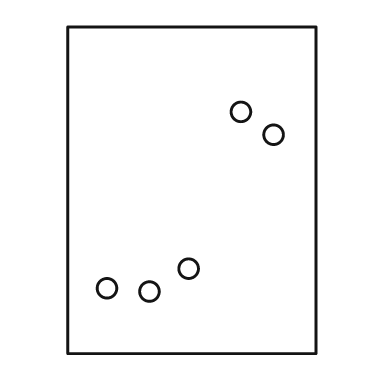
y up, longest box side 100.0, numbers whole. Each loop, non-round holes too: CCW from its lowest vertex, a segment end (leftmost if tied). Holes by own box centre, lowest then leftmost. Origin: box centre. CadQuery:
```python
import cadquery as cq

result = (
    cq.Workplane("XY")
    .moveTo(-38.0, -50.0)
    .lineTo(38.0, -50.0)
    .lineTo(38.0, 50.0)
    .lineTo(-38.0, 50.0)
    .close()
    .moveTo(-13.0, -31.0)
    .circle(3.0)
    .moveTo(-26.0, -30.0)
    .circle(3.0)
    .moveTo(-1.0, -24.0)
    .circle(3.0)
    .moveTo(25.0, 17.0)
    .circle(3.0)
    .moveTo(15.0, 24.0)
    .circle(3.0)
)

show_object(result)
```